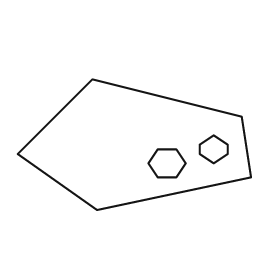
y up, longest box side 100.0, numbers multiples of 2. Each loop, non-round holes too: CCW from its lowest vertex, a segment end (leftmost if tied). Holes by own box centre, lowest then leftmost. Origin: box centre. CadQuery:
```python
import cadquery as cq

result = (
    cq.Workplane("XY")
    .moveTo(-16.0, -28.0)
    .lineTo(50.0, -14.0)
    .lineTo(46.0, 12.0)
    .lineTo(-18.0, 28.0)
    .lineTo(-50.0, -4.0)
    .close()
    .moveTo(10.0, -14.0)
    .lineTo(18.0, -14.0)
    .lineTo(22.0, -8.0)
    .lineTo(18.0, -2.0)
    .lineTo(10.0, -2.0)
    .lineTo(6.0, -8.0)
    .close()
    .moveTo(34.0, -8.0)
    .lineTo(40.0, -4.0)
    .lineTo(40.0, 0.0)
    .lineTo(34.0, 4.0)
    .lineTo(28.0, 0.0)
    .lineTo(28.0, -4.0)
    .close()
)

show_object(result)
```